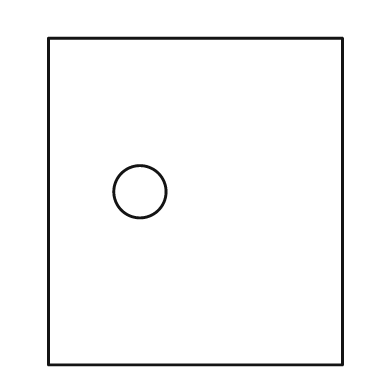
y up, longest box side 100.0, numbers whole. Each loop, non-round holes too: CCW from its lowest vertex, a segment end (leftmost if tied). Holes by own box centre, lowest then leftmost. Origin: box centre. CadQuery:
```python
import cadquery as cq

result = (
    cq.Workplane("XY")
    .moveTo(-45.0, -50.0)
    .lineTo(45.0, -50.0)
    .lineTo(45.0, 50.0)
    .lineTo(-45.0, 50.0)
    .close()
    .moveTo(-17.0, 3.0)
    .circle(8.0)
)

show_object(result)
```